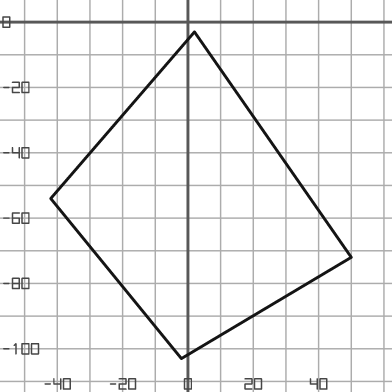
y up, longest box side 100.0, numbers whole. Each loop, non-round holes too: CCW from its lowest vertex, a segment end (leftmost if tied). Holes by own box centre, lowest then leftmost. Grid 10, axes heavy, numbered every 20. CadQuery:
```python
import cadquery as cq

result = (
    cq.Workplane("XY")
    .moveTo(-2.0, -103.0)
    .lineTo(50.0, -72.0)
    .lineTo(2.0, -3.0)
    .lineTo(-42.0, -54.0)
    .close()
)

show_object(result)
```